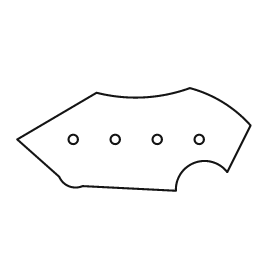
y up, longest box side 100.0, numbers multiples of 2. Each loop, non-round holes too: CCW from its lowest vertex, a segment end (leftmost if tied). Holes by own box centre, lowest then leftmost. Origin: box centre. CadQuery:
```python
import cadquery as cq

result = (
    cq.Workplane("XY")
    .moveTo(18.0, -22.0)
    .threePointArc((26.0, -10.0), (40.0, -14.0))
    .lineTo(50.0, 6.0)
    .threePointArc((38.0, 16.0), (24.0, 22.0))
    .threePointArc((4.0, 18.0), (-16.0, 20.0))
    .lineTo(-50.0, 0.0)
    .lineTo(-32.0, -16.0)
    .threePointArc((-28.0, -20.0), (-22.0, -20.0))
    .close()
    .moveTo(-26.0, 0.0)
    .circle(2.0)
    .moveTo(-8.0, 0.0)
    .circle(2.0)
    .moveTo(10.0, 0.0)
    .circle(2.0)
    .moveTo(28.0, 0.0)
    .circle(2.0)
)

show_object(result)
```